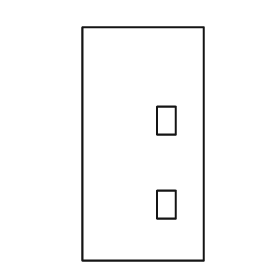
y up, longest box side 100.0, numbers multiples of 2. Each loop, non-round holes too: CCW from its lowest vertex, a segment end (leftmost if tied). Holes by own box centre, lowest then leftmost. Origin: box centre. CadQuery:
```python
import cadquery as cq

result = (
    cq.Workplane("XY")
    .moveTo(-26.0, -50.0)
    .lineTo(26.0, -50.0)
    .lineTo(26.0, 50.0)
    .lineTo(-26.0, 50.0)
    .close()
    .moveTo(6.0, -32.0)
    .lineTo(14.0, -32.0)
    .lineTo(14.0, -20.0)
    .lineTo(6.0, -20.0)
    .close()
    .moveTo(6.0, 4.0)
    .lineTo(14.0, 4.0)
    .lineTo(14.0, 16.0)
    .lineTo(6.0, 16.0)
    .close()
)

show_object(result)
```